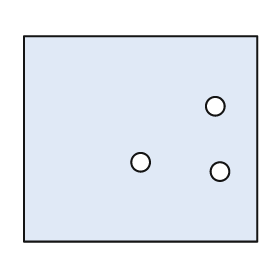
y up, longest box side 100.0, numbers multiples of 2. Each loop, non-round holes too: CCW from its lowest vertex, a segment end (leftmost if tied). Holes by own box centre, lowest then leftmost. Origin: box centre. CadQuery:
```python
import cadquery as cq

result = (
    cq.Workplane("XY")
    .moveTo(-50.0, -44.0)
    .lineTo(50.0, -44.0)
    .lineTo(50.0, 44.0)
    .lineTo(-50.0, 44.0)
    .close()
    .moveTo(34.0, -14.0)
    .circle(4.0)
    .moveTo(0.0, -10.0)
    .circle(4.0)
    .moveTo(32.0, 14.0)
    .circle(4.0)
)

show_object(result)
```